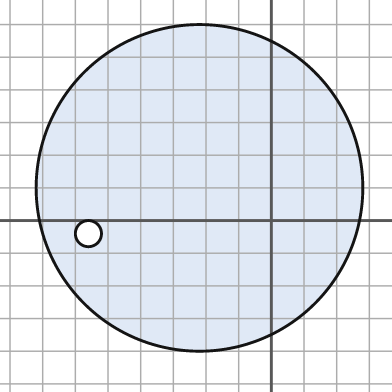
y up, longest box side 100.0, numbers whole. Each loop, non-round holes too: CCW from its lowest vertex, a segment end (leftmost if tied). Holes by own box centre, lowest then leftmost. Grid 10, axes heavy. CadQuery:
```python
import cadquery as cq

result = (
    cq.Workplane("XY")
    .moveTo(-22.0, 10.0)
    .circle(50.0)
    .moveTo(-56.0, -4.0)
    .circle(4.0)
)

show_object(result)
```